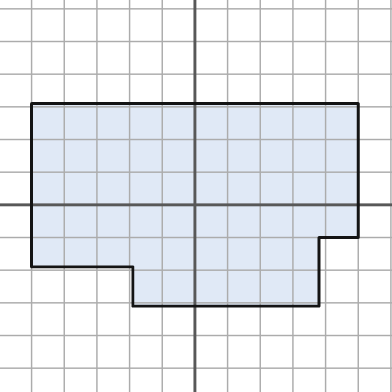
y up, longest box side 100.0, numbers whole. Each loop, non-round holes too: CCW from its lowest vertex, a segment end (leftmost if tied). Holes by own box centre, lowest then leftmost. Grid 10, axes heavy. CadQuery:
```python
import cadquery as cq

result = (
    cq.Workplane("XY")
    .moveTo(-19.0, -31.0)
    .lineTo(38.0, -31.0)
    .lineTo(38.0, -10.0)
    .lineTo(50.0, -10.0)
    .lineTo(50.0, 31.0)
    .lineTo(-50.0, 31.0)
    .lineTo(-50.0, -19.0)
    .lineTo(-19.0, -19.0)
    .close()
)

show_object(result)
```